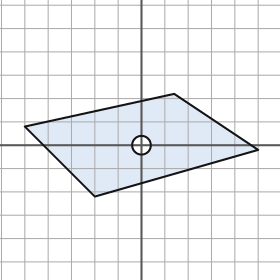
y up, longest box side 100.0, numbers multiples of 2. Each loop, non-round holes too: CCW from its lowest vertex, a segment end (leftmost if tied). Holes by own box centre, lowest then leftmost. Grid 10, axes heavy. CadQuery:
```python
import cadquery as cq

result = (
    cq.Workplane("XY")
    .moveTo(-20.0, -22.0)
    .lineTo(50.0, -2.0)
    .lineTo(14.0, 22.0)
    .lineTo(-50.0, 8.0)
    .close()
    .moveTo(0.0, 0.0)
    .circle(4.0)
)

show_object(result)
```